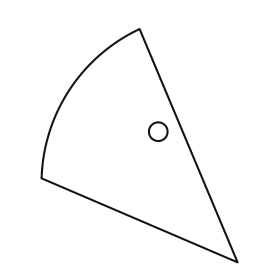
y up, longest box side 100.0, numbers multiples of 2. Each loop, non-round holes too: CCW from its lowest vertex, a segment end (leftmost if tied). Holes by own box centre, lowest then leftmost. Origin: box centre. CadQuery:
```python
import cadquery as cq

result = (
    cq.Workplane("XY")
    .moveTo(42.0, -50.0)
    .lineTo(0.0, 50.0)
    .threePointArc((-30.0, 24.0), (-42.0, -14.0))
    .close()
    .moveTo(8.0, 6.0)
    .circle(4.0)
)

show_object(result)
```